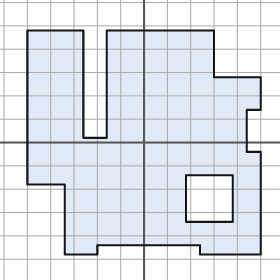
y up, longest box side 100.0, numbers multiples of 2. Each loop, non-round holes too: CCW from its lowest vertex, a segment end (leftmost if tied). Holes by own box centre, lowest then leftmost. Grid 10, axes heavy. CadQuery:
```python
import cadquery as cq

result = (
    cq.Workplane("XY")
    .moveTo(-34.0, -48.0)
    .lineTo(-20.0, -48.0)
    .lineTo(-20.0, -44.0)
    .lineTo(24.0, -44.0)
    .lineTo(24.0, -48.0)
    .lineTo(50.0, -48.0)
    .lineTo(50.0, -4.0)
    .lineTo(44.0, -4.0)
    .lineTo(44.0, 14.0)
    .lineTo(50.0, 14.0)
    .lineTo(50.0, 28.0)
    .lineTo(30.0, 28.0)
    .lineTo(30.0, 48.0)
    .lineTo(-16.0, 48.0)
    .lineTo(-16.0, 2.0)
    .lineTo(-26.0, 2.0)
    .lineTo(-26.0, 48.0)
    .lineTo(-50.0, 48.0)
    .lineTo(-50.0, -18.0)
    .lineTo(-34.0, -18.0)
    .close()
    .moveTo(18.0, -34.0)
    .lineTo(38.0, -34.0)
    .lineTo(38.0, -14.0)
    .lineTo(18.0, -14.0)
    .close()
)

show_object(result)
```